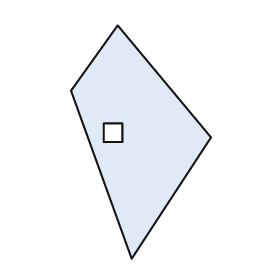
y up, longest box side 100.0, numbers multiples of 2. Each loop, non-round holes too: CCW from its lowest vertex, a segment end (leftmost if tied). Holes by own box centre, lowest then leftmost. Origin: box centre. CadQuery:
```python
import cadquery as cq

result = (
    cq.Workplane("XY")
    .moveTo(-4.0, -50.0)
    .lineTo(30.0, 2.0)
    .lineTo(-10.0, 50.0)
    .lineTo(-30.0, 22.0)
    .close()
    .moveTo(-16.0, 0.0)
    .lineTo(-8.0, 0.0)
    .lineTo(-8.0, 8.0)
    .lineTo(-16.0, 8.0)
    .close()
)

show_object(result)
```